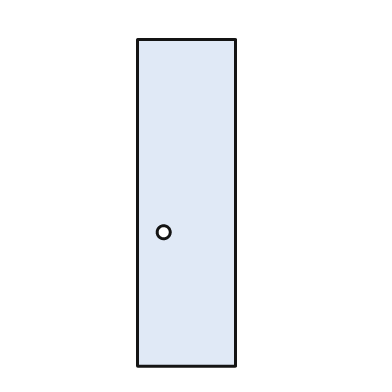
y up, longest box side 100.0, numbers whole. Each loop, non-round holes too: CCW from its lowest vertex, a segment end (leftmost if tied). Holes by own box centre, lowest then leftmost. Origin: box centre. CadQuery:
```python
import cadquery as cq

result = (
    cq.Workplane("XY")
    .moveTo(-15.0, -50.0)
    .lineTo(15.0, -50.0)
    .lineTo(15.0, 50.0)
    .lineTo(-15.0, 50.0)
    .close()
    .moveTo(-7.0, -9.0)
    .circle(2.0)
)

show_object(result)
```